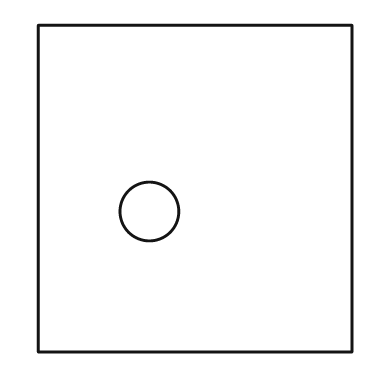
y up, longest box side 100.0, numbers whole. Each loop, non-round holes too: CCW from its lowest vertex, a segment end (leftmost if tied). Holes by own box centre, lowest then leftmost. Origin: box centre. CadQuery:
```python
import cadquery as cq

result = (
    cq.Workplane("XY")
    .moveTo(-48.0, -50.0)
    .lineTo(48.0, -50.0)
    .lineTo(48.0, 50.0)
    .lineTo(-48.0, 50.0)
    .close()
    .moveTo(-14.0, -7.0)
    .circle(9.0)
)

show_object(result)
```